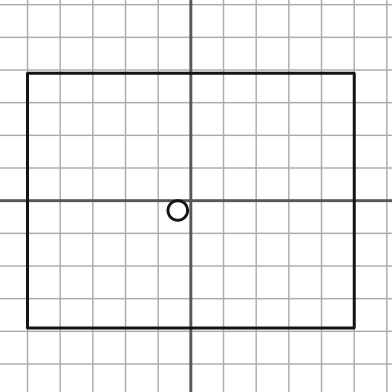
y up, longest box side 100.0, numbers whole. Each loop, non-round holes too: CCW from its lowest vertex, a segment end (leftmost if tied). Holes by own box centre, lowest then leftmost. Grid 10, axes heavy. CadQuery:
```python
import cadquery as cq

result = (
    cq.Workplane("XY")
    .moveTo(-50.0, -39.0)
    .lineTo(50.0, -39.0)
    .lineTo(50.0, 39.0)
    .lineTo(-50.0, 39.0)
    .close()
    .moveTo(-4.0, -3.0)
    .circle(3.0)
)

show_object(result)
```